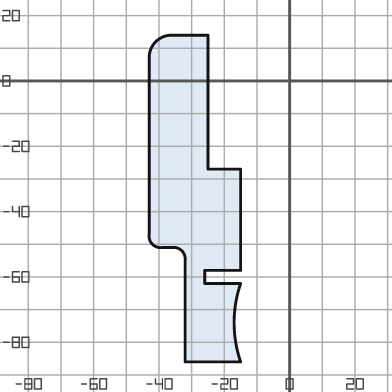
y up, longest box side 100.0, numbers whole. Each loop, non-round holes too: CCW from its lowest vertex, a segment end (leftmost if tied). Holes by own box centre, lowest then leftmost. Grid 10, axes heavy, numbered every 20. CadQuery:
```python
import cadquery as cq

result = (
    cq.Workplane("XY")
    .moveTo(-32.0, -86.0)
    .lineTo(-15.0, -86.0)
    .threePointArc((-17.0, -74.0), (-15.0, -62.0))
    .lineTo(-26.0, -62.0)
    .lineTo(-26.0, -58.0)
    .lineTo(-15.0, -58.0)
    .lineTo(-15.0, -27.0)
    .lineTo(-25.0, -27.0)
    .lineTo(-25.0, 14.0)
    .lineTo(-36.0, 14.0)
    .threePointArc((-41.0, 12.0), (-43.0, 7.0))
    .lineTo(-43.0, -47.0)
    .threePointArc((-42.0, -50.0), (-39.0, -51.0))
    .lineTo(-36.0, -51.0)
    .threePointArc((-33.0, -52.0), (-32.0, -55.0))
    .close()
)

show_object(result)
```